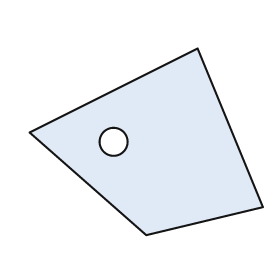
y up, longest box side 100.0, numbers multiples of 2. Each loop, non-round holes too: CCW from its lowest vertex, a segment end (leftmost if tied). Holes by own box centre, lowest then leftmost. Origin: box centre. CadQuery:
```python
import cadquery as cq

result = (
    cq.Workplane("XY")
    .moveTo(0.0, -40.0)
    .lineTo(50.0, -28.0)
    .lineTo(22.0, 40.0)
    .lineTo(-50.0, 4.0)
    .close()
    .moveTo(-14.0, 0.0)
    .circle(6.0)
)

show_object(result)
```